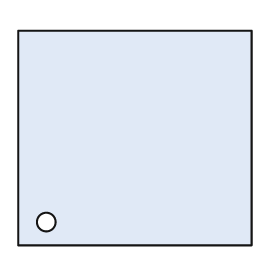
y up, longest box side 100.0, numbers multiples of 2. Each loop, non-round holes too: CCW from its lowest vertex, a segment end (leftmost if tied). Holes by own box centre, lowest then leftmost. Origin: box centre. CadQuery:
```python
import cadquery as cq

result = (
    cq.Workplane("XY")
    .moveTo(-50.0, -46.0)
    .lineTo(50.0, -46.0)
    .lineTo(50.0, 46.0)
    .lineTo(-50.0, 46.0)
    .close()
    .moveTo(-38.0, -36.0)
    .circle(4.0)
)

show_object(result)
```